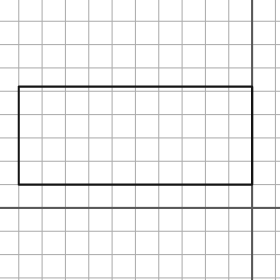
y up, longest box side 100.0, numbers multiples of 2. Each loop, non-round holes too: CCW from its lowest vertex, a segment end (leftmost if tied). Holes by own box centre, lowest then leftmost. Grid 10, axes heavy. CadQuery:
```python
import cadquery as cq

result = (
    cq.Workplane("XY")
    .moveTo(-100.0, 10.0)
    .lineTo(0.0, 10.0)
    .lineTo(0.0, 52.0)
    .lineTo(-100.0, 52.0)
    .close()
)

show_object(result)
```